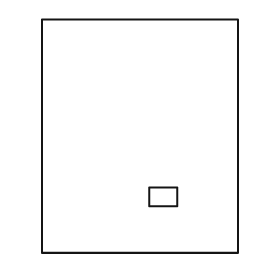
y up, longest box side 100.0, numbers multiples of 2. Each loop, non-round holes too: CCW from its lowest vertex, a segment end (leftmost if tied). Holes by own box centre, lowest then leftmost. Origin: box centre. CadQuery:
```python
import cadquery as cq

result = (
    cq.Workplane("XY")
    .moveTo(-42.0, -50.0)
    .lineTo(42.0, -50.0)
    .lineTo(42.0, 50.0)
    .lineTo(-42.0, 50.0)
    .close()
    .moveTo(4.0, -30.0)
    .lineTo(16.0, -30.0)
    .lineTo(16.0, -22.0)
    .lineTo(4.0, -22.0)
    .close()
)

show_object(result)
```